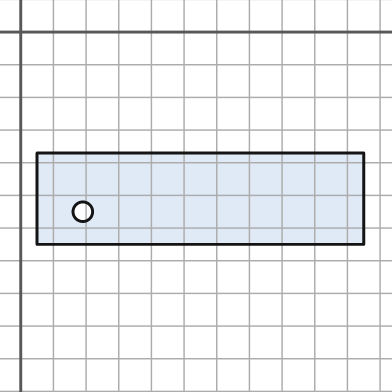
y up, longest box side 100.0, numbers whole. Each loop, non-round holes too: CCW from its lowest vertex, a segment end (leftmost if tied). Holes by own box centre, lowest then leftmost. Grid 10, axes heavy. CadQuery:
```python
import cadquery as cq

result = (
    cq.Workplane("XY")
    .moveTo(5.0, -65.0)
    .lineTo(105.0, -65.0)
    .lineTo(105.0, -37.0)
    .lineTo(5.0, -37.0)
    .close()
    .moveTo(19.0, -55.0)
    .circle(3.0)
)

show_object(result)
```